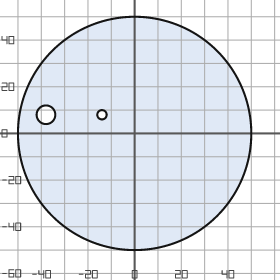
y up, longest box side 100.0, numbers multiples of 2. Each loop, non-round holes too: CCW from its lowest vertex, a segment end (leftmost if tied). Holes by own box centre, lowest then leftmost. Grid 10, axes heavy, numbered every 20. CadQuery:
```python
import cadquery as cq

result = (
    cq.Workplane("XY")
    .moveTo(0.0, 0.0)
    .circle(50.0)
    .moveTo(-38.0, 8.0)
    .circle(4.0)
    .moveTo(-14.0, 8.0)
    .circle(2.0)
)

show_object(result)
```